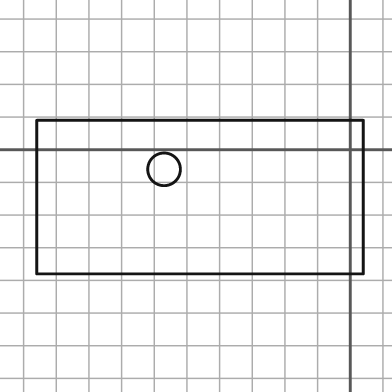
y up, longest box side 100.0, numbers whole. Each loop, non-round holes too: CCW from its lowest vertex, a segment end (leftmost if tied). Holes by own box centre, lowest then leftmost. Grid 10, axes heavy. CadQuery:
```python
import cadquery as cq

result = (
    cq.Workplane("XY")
    .moveTo(-96.0, -38.0)
    .lineTo(4.0, -38.0)
    .lineTo(4.0, 9.0)
    .lineTo(-96.0, 9.0)
    .close()
    .moveTo(-57.0, -6.0)
    .circle(5.0)
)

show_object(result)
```